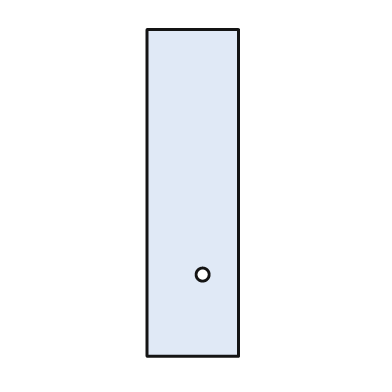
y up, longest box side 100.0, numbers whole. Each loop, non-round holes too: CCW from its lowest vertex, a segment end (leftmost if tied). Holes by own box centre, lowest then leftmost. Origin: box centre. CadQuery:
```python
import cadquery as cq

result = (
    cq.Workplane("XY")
    .moveTo(-14.0, -50.0)
    .lineTo(14.0, -50.0)
    .lineTo(14.0, 50.0)
    .lineTo(-14.0, 50.0)
    .close()
    .moveTo(3.0, -25.0)
    .circle(2.0)
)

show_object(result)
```